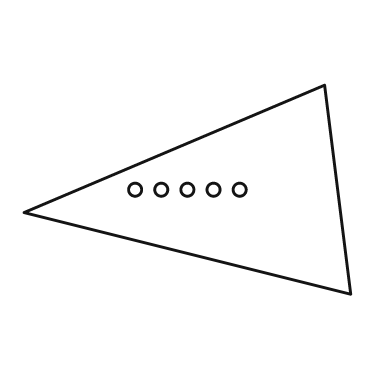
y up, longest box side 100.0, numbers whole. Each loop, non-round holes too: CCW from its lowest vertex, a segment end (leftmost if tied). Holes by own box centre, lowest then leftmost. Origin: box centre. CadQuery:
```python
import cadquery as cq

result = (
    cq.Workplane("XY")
    .moveTo(50.0, -32.0)
    .lineTo(42.0, 32.0)
    .lineTo(-50.0, -7.0)
    .close()
    .moveTo(-16.0, 0.0)
    .circle(2.0)
    .moveTo(-8.0, 0.0)
    .circle(2.0)
    .moveTo(0.0, 0.0)
    .circle(2.0)
    .moveTo(8.0, 0.0)
    .circle(2.0)
    .moveTo(16.0, 0.0)
    .circle(2.0)
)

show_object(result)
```